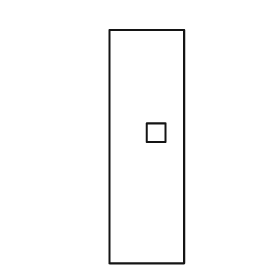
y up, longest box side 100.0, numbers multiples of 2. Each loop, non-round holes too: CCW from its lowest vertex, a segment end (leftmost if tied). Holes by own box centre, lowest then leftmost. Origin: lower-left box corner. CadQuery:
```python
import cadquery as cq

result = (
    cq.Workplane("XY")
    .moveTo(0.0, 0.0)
    .lineTo(32.0, 0.0)
    .lineTo(32.0, 100.0)
    .lineTo(0.0, 100.0)
    .close()
    .moveTo(16.0, 52.0)
    .lineTo(24.0, 52.0)
    .lineTo(24.0, 60.0)
    .lineTo(16.0, 60.0)
    .close()
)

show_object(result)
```